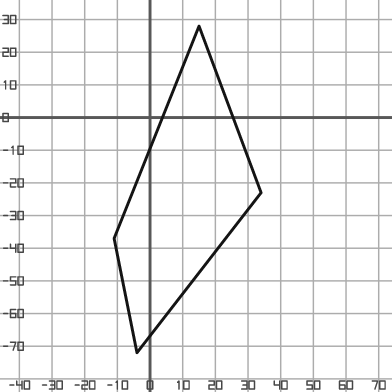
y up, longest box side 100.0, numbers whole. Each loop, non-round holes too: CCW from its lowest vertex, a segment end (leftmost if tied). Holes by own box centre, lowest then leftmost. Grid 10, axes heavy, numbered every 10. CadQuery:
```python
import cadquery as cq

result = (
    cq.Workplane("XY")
    .moveTo(-4.0, -72.0)
    .lineTo(34.0, -23.0)
    .lineTo(15.0, 28.0)
    .lineTo(-11.0, -37.0)
    .close()
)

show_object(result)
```